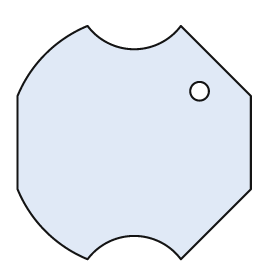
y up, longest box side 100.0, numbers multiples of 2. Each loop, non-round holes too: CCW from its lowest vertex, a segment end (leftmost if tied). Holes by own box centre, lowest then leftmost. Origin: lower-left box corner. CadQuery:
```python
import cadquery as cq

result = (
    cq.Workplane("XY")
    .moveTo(30.0, 0.0)
    .threePointArc((50.0, 10.0), (70.0, 0.0))
    .lineTo(100.0, 30.0)
    .lineTo(100.0, 70.0)
    .lineTo(70.0, 100.0)
    .threePointArc((50.0, 90.0), (30.0, 100.0))
    .threePointArc((12.0, 88.0), (0.0, 70.0))
    .lineTo(0.0, 30.0)
    .threePointArc((12.0, 12.0), (30.0, 0.0))
    .close()
    .moveTo(78.0, 72.0)
    .circle(4.0)
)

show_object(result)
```